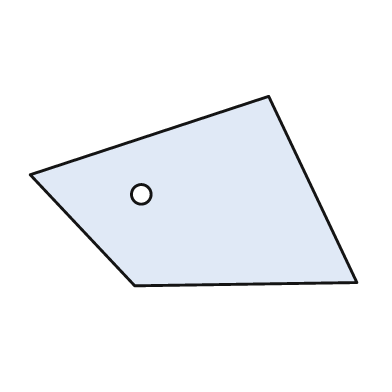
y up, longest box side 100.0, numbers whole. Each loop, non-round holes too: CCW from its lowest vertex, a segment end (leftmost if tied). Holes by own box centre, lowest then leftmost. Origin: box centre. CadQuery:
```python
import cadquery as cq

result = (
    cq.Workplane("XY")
    .moveTo(-18.0, -29.0)
    .lineTo(50.0, -28.0)
    .lineTo(23.0, 29.0)
    .lineTo(-50.0, 5.0)
    .close()
    .moveTo(-16.0, -1.0)
    .circle(3.0)
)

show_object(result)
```